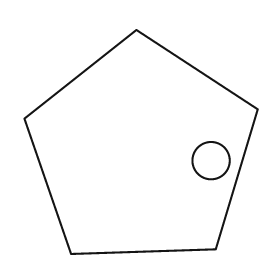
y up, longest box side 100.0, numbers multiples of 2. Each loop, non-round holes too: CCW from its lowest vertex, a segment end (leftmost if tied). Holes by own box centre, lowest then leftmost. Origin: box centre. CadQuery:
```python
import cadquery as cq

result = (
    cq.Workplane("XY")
    .moveTo(-30.0, -48.0)
    .lineTo(32.0, -46.0)
    .lineTo(50.0, 14.0)
    .lineTo(-2.0, 48.0)
    .lineTo(-50.0, 10.0)
    .close()
    .moveTo(30.0, -8.0)
    .circle(8.0)
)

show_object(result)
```